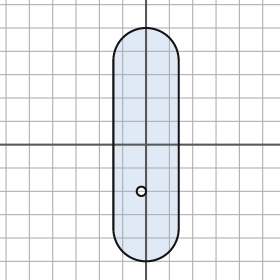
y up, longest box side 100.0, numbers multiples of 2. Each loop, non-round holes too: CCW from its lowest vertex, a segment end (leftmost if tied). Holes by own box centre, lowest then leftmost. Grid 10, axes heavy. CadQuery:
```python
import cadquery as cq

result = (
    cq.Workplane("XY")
    .moveTo(-14.0, -36.0)
    .threePointArc((0.0, -50.0), (14.0, -36.0))
    .lineTo(14.0, 36.0)
    .threePointArc((0.0, 50.0), (-14.0, 36.0))
    .close()
    .moveTo(-2.0, -20.0)
    .circle(2.0)
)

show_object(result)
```